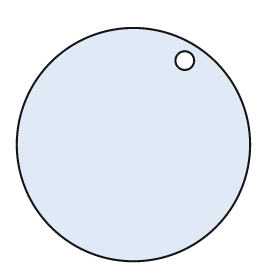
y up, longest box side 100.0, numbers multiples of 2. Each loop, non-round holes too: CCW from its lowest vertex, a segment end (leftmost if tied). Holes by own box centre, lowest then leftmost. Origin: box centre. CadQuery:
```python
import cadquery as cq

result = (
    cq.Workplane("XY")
    .moveTo(0.0, 0.0)
    .circle(50.0)
    .moveTo(22.0, 36.0)
    .circle(4.0)
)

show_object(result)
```